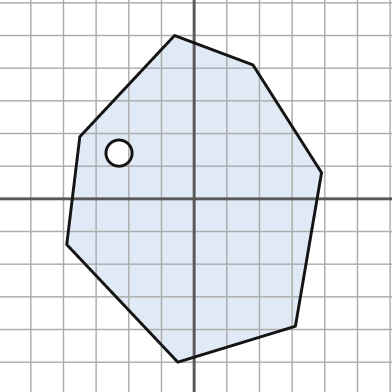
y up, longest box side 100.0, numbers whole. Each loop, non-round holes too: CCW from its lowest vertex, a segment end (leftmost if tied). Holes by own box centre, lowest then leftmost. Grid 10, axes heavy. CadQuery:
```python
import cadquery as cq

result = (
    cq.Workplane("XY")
    .moveTo(-5.0, -50.0)
    .lineTo(31.0, -39.0)
    .lineTo(39.0, 8.0)
    .lineTo(18.0, 41.0)
    .lineTo(-6.0, 50.0)
    .lineTo(-35.0, 19.0)
    .lineTo(-39.0, -14.0)
    .close()
    .moveTo(-23.0, 14.0)
    .circle(4.0)
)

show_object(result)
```